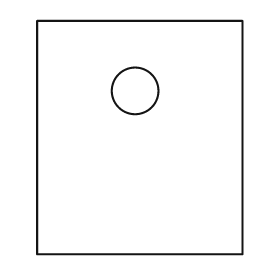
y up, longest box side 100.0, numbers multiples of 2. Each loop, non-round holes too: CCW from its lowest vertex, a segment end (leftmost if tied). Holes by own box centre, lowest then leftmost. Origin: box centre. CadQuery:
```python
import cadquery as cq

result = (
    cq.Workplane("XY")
    .moveTo(-44.0, -50.0)
    .lineTo(44.0, -50.0)
    .lineTo(44.0, 50.0)
    .lineTo(-44.0, 50.0)
    .close()
    .moveTo(-2.0, 20.0)
    .circle(10.0)
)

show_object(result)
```